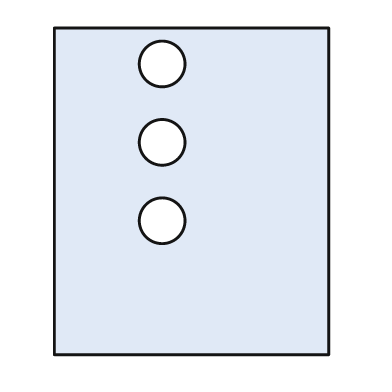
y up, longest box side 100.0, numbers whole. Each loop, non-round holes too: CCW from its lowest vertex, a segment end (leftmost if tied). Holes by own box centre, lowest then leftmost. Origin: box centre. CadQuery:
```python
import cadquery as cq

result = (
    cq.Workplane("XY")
    .moveTo(-42.0, -50.0)
    .lineTo(42.0, -50.0)
    .lineTo(42.0, 50.0)
    .lineTo(-42.0, 50.0)
    .close()
    .moveTo(-9.0, -9.0)
    .circle(7.0)
    .moveTo(-9.0, 15.0)
    .circle(7.0)
    .moveTo(-9.0, 39.0)
    .circle(7.0)
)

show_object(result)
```